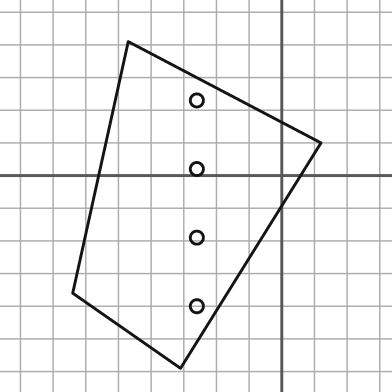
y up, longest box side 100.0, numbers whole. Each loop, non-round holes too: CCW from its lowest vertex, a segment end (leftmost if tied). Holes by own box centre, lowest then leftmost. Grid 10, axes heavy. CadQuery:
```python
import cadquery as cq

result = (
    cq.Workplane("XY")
    .moveTo(-31.0, -59.0)
    .lineTo(12.0, 10.0)
    .lineTo(-47.0, 41.0)
    .lineTo(-64.0, -36.0)
    .close()
    .moveTo(-26.0, -40.0)
    .circle(2.0)
    .moveTo(-26.0, -19.0)
    .circle(2.0)
    .moveTo(-26.0, 2.0)
    .circle(2.0)
    .moveTo(-26.0, 23.0)
    .circle(2.0)
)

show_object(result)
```